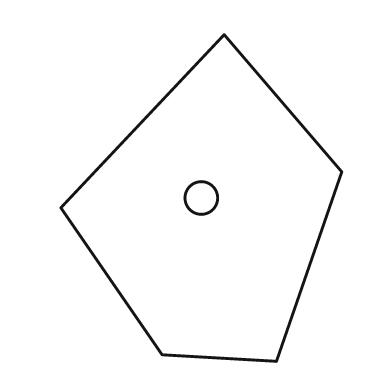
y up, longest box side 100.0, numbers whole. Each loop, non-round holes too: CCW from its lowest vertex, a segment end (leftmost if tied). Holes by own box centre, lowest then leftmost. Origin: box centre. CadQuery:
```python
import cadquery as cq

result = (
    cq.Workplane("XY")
    .moveTo(23.0, -50.0)
    .lineTo(43.0, 8.0)
    .lineTo(7.0, 50.0)
    .lineTo(-43.0, -3.0)
    .lineTo(-12.0, -48.0)
    .close()
    .moveTo(0.0, 0.0)
    .circle(5.0)
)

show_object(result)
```